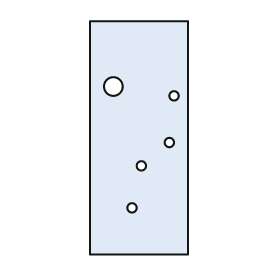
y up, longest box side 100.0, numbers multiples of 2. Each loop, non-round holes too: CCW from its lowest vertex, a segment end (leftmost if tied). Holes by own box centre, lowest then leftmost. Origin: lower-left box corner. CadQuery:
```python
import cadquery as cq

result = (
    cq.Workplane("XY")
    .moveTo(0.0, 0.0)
    .lineTo(42.0, 0.0)
    .lineTo(42.0, 100.0)
    .lineTo(0.0, 100.0)
    .close()
    .moveTo(18.0, 20.0)
    .circle(2.0)
    .moveTo(22.0, 38.0)
    .circle(2.0)
    .moveTo(34.0, 48.0)
    .circle(2.0)
    .moveTo(36.0, 68.0)
    .circle(2.0)
    .moveTo(10.0, 72.0)
    .circle(4.0)
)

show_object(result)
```